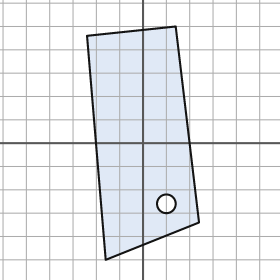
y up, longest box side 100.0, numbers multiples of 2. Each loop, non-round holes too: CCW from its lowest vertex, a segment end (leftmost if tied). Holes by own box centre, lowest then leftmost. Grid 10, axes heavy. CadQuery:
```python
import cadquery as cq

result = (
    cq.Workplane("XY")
    .moveTo(-16.0, -50.0)
    .lineTo(24.0, -34.0)
    .lineTo(14.0, 50.0)
    .lineTo(-24.0, 46.0)
    .close()
    .moveTo(10.0, -26.0)
    .circle(4.0)
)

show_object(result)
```